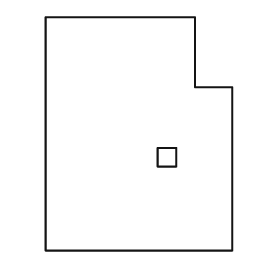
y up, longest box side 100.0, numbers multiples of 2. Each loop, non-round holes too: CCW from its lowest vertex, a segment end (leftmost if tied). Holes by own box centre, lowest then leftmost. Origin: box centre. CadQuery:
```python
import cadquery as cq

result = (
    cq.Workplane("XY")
    .moveTo(-40.0, -50.0)
    .lineTo(40.0, -50.0)
    .lineTo(40.0, 20.0)
    .lineTo(24.0, 20.0)
    .lineTo(24.0, 50.0)
    .lineTo(-40.0, 50.0)
    .close()
    .moveTo(8.0, -14.0)
    .lineTo(16.0, -14.0)
    .lineTo(16.0, -6.0)
    .lineTo(8.0, -6.0)
    .close()
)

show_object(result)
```